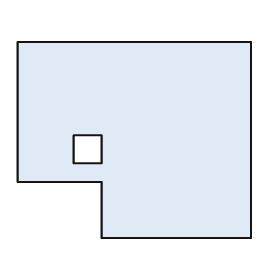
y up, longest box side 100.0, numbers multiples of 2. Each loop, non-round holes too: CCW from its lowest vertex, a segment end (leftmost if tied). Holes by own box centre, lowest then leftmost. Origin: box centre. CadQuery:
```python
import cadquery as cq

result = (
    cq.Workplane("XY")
    .moveTo(-14.0, -42.0)
    .lineTo(50.0, -42.0)
    .lineTo(50.0, 42.0)
    .lineTo(-50.0, 42.0)
    .lineTo(-50.0, -18.0)
    .lineTo(-14.0, -18.0)
    .close()
    .moveTo(-26.0, -10.0)
    .lineTo(-14.0, -10.0)
    .lineTo(-14.0, 2.0)
    .lineTo(-26.0, 2.0)
    .close()
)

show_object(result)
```